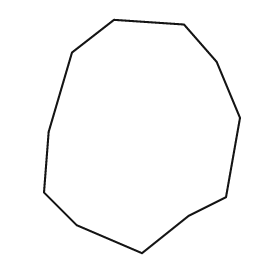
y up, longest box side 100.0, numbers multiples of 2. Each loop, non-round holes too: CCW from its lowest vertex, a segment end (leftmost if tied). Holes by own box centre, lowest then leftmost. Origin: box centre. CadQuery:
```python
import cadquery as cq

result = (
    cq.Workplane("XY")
    .moveTo(0.0, -50.0)
    .lineTo(20.0, -34.0)
    .lineTo(36.0, -26.0)
    .lineTo(42.0, 8.0)
    .lineTo(32.0, 32.0)
    .lineTo(18.0, 48.0)
    .lineTo(-12.0, 50.0)
    .lineTo(-30.0, 36.0)
    .lineTo(-40.0, 2.0)
    .lineTo(-42.0, -24.0)
    .lineTo(-28.0, -38.0)
    .close()
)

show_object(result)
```